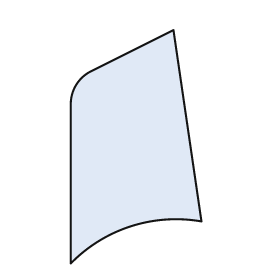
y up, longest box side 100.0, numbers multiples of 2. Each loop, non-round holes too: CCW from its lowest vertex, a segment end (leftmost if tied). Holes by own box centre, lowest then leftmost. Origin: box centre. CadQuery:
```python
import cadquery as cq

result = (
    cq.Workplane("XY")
    .moveTo(-28.0, -50.0)
    .threePointArc((-2.0, -34.0), (28.0, -32.0))
    .lineTo(16.0, 50.0)
    .lineTo(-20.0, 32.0)
    .threePointArc((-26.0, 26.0), (-28.0, 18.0))
    .close()
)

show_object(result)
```